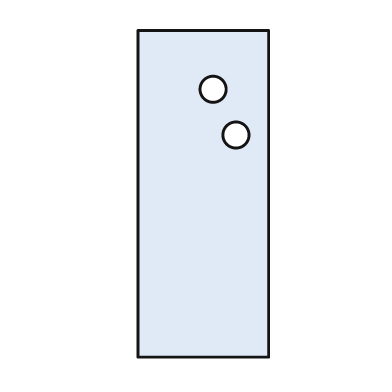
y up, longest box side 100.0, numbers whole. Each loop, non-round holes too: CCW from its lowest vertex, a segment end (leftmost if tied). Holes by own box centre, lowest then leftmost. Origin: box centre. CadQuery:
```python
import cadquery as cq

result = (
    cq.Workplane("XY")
    .moveTo(-20.0, -50.0)
    .lineTo(20.0, -50.0)
    .lineTo(20.0, 50.0)
    .lineTo(-20.0, 50.0)
    .close()
    .moveTo(10.0, 18.0)
    .circle(4.0)
    .moveTo(3.0, 32.0)
    .circle(4.0)
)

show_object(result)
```